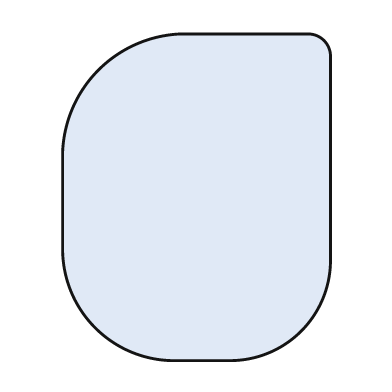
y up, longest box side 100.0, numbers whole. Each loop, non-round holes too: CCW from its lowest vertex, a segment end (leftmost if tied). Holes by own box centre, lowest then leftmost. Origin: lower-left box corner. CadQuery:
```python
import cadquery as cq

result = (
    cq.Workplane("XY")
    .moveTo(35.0, 0.0)
    .lineTo(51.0, 0.0)
    .threePointArc((73.0, 9.0), (82.0, 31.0))
    .lineTo(82.0, 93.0)
    .threePointArc((80.0, 98.0), (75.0, 100.0))
    .lineTo(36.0, 100.0)
    .threePointArc((11.0, 89.0), (0.0, 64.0))
    .lineTo(0.0, 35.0)
    .threePointArc((10.0, 10.0), (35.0, 0.0))
    .close()
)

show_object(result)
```